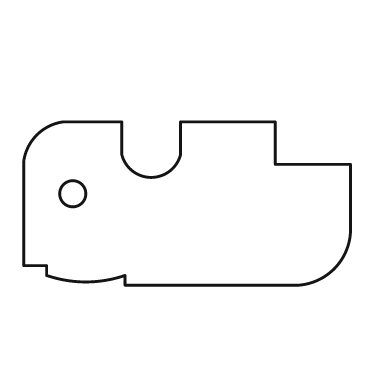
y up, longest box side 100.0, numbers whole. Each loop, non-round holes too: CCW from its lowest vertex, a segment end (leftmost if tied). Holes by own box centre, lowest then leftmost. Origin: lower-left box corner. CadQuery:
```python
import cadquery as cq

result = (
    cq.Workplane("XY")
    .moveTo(31.0, 0.0)
    .lineTo(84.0, 0.0)
    .threePointArc((95.0, 5.0), (100.0, 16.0))
    .lineTo(100.0, 37.0)
    .lineTo(77.0, 37.0)
    .lineTo(77.0, 50.0)
    .lineTo(48.0, 50.0)
    .lineTo(48.0, 40.0)
    .threePointArc((39.0, 33.0), (30.0, 40.0))
    .lineTo(30.0, 50.0)
    .lineTo(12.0, 50.0)
    .threePointArc((4.0, 46.0), (0.0, 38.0))
    .lineTo(0.0, 6.0)
    .lineTo(7.0, 6.0)
    .lineTo(7.0, 3.0)
    .threePointArc((19.0, 1.0), (31.0, 3.0))
    .close()
    .moveTo(15.0, 28.0)
    .circle(4.0)
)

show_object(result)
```